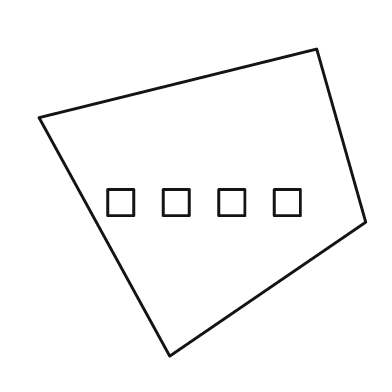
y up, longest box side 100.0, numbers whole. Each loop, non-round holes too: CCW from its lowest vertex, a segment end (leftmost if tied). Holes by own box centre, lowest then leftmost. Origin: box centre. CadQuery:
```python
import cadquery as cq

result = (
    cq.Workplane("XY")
    .moveTo(-10.0, -47.0)
    .lineTo(50.0, -6.0)
    .lineTo(35.0, 47.0)
    .lineTo(-50.0, 26.0)
    .close()
    .moveTo(-29.0, -4.0)
    .lineTo(-21.0, -4.0)
    .lineTo(-21.0, 4.0)
    .lineTo(-29.0, 4.0)
    .close()
    .moveTo(-12.0, -4.0)
    .lineTo(-4.0, -4.0)
    .lineTo(-4.0, 4.0)
    .lineTo(-12.0, 4.0)
    .close()
    .moveTo(5.0, -4.0)
    .lineTo(13.0, -4.0)
    .lineTo(13.0, 4.0)
    .lineTo(5.0, 4.0)
    .close()
    .moveTo(22.0, -4.0)
    .lineTo(30.0, -4.0)
    .lineTo(30.0, 4.0)
    .lineTo(22.0, 4.0)
    .close()
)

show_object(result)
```